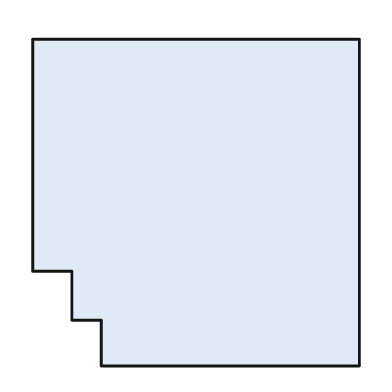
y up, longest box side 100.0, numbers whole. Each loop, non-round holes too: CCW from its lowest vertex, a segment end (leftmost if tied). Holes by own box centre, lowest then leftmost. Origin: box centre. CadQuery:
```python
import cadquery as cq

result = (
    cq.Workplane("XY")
    .moveTo(-29.0, -50.0)
    .lineTo(50.0, -50.0)
    .lineTo(50.0, 50.0)
    .lineTo(-50.0, 50.0)
    .lineTo(-50.0, -21.0)
    .lineTo(-38.0, -21.0)
    .lineTo(-38.0, -36.0)
    .lineTo(-29.0, -36.0)
    .close()
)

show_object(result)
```